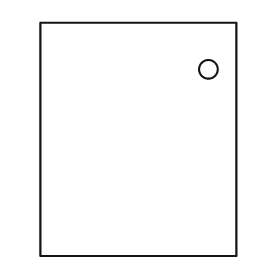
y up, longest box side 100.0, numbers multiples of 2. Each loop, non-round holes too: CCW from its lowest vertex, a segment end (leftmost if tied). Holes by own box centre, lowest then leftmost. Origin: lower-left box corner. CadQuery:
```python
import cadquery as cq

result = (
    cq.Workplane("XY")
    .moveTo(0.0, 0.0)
    .lineTo(84.0, 0.0)
    .lineTo(84.0, 100.0)
    .lineTo(0.0, 100.0)
    .close()
    .moveTo(72.0, 80.0)
    .circle(4.0)
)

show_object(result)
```